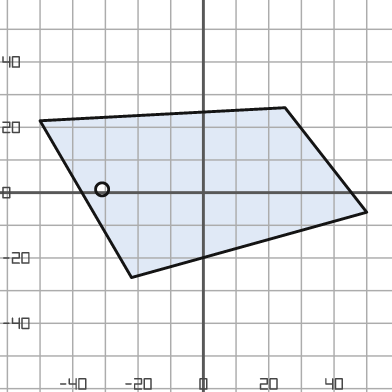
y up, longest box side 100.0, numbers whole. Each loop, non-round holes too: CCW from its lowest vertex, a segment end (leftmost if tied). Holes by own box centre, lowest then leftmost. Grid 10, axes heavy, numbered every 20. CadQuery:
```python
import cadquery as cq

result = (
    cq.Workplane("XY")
    .moveTo(-22.0, -26.0)
    .lineTo(50.0, -6.0)
    .lineTo(25.0, 26.0)
    .lineTo(-50.0, 22.0)
    .close()
    .moveTo(-31.0, 1.0)
    .circle(2.0)
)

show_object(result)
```